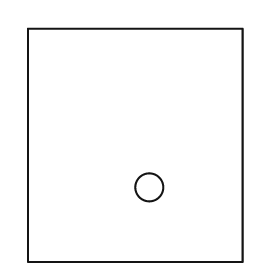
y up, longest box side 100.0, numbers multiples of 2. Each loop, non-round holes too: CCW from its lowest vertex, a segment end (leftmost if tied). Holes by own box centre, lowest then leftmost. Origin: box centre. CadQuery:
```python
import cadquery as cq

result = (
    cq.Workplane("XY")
    .moveTo(-46.0, -50.0)
    .lineTo(46.0, -50.0)
    .lineTo(46.0, 50.0)
    .lineTo(-46.0, 50.0)
    .close()
    .moveTo(6.0, -18.0)
    .circle(6.0)
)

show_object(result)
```